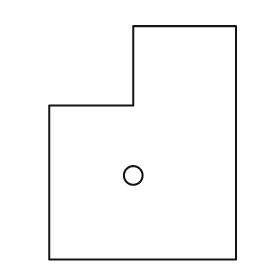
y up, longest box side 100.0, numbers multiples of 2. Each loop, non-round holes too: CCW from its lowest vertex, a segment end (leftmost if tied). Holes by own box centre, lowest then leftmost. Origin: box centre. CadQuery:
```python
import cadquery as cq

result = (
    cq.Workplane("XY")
    .moveTo(-40.0, -50.0)
    .lineTo(40.0, -50.0)
    .lineTo(40.0, 50.0)
    .lineTo(-4.0, 50.0)
    .lineTo(-4.0, 16.0)
    .lineTo(-40.0, 16.0)
    .close()
    .moveTo(-4.0, -14.0)
    .circle(4.0)
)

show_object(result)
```